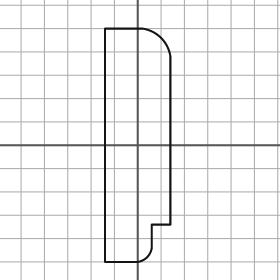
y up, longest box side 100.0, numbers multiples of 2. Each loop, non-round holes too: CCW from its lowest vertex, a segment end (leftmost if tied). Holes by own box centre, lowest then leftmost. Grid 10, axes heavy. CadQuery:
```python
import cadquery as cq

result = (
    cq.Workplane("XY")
    .moveTo(-14.0, -50.0)
    .lineTo(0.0, -50.0)
    .threePointArc((4.0, -48.0), (6.0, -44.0))
    .lineTo(6.0, -34.0)
    .lineTo(14.0, -34.0)
    .lineTo(14.0, 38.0)
    .threePointArc((10.0, 46.0), (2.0, 50.0))
    .lineTo(-14.0, 50.0)
    .close()
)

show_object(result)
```